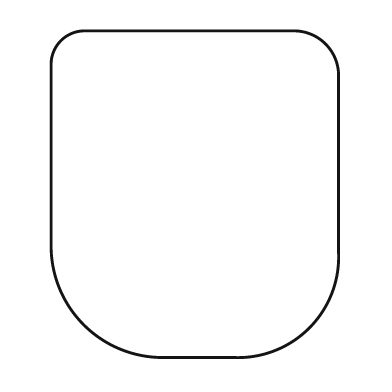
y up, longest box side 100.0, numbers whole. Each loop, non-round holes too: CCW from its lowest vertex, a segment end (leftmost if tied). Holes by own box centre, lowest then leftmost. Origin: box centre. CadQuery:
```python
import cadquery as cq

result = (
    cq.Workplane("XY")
    .moveTo(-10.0, -50.0)
    .lineTo(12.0, -50.0)
    .threePointArc((35.0, -41.0), (44.0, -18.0))
    .lineTo(44.0, 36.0)
    .threePointArc((40.0, 46.0), (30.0, 50.0))
    .lineTo(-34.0, 50.0)
    .threePointArc((-41.0, 47.0), (-44.0, 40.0))
    .lineTo(-44.0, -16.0)
    .threePointArc((-34.0, -40.0), (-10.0, -50.0))
    .close()
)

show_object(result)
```